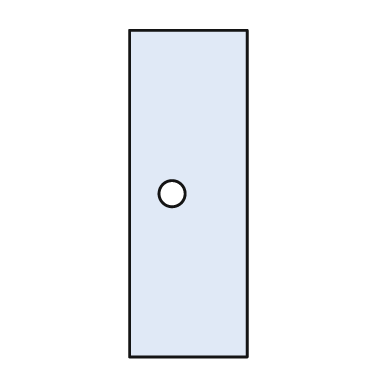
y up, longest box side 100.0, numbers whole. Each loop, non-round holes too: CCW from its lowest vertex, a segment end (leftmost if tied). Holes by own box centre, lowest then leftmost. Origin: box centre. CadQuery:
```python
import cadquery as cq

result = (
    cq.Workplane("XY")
    .moveTo(-18.0, -50.0)
    .lineTo(18.0, -50.0)
    .lineTo(18.0, 50.0)
    .lineTo(-18.0, 50.0)
    .close()
    .moveTo(-5.0, 0.0)
    .circle(4.0)
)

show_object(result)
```